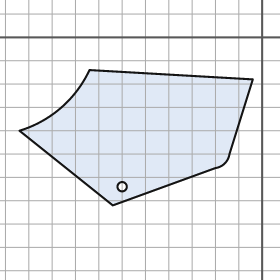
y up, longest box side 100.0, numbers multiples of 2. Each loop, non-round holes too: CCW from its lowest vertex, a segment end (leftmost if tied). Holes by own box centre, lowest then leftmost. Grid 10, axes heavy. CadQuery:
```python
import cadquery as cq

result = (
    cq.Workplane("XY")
    .moveTo(-64.0, -72.0)
    .lineTo(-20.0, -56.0)
    .threePointArc((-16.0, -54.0), (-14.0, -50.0))
    .lineTo(-4.0, -18.0)
    .lineTo(-74.0, -14.0)
    .threePointArc((-86.0, -30.0), (-104.0, -40.0))
    .close()
    .moveTo(-60.0, -64.0)
    .circle(2.0)
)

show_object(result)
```